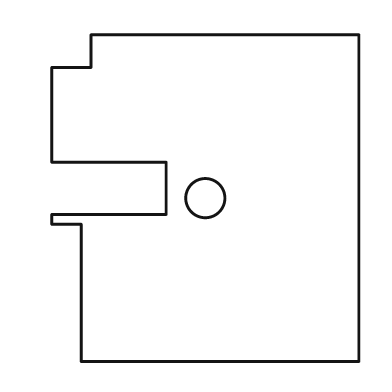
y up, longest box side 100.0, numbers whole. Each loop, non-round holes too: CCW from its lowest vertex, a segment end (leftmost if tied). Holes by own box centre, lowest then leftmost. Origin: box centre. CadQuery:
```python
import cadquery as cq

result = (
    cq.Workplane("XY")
    .moveTo(-38.0, -50.0)
    .lineTo(47.0, -50.0)
    .lineTo(47.0, 50.0)
    .lineTo(-35.0, 50.0)
    .lineTo(-35.0, 40.0)
    .lineTo(-47.0, 40.0)
    .lineTo(-47.0, 11.0)
    .lineTo(-12.0, 11.0)
    .lineTo(-12.0, -5.0)
    .lineTo(-47.0, -5.0)
    .lineTo(-47.0, -8.0)
    .lineTo(-38.0, -8.0)
    .close()
    .moveTo(0.0, 0.0)
    .circle(6.0)
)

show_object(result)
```